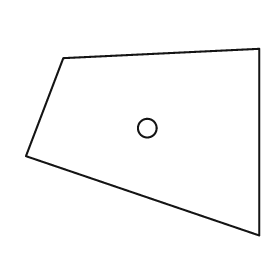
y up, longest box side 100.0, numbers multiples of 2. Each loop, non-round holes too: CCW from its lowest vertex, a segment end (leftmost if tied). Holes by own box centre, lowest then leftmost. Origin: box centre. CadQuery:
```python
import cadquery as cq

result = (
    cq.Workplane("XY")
    .moveTo(50.0, -40.0)
    .lineTo(50.0, 40.0)
    .lineTo(-34.0, 36.0)
    .lineTo(-50.0, -6.0)
    .close()
    .moveTo(2.0, 6.0)
    .circle(4.0)
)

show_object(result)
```